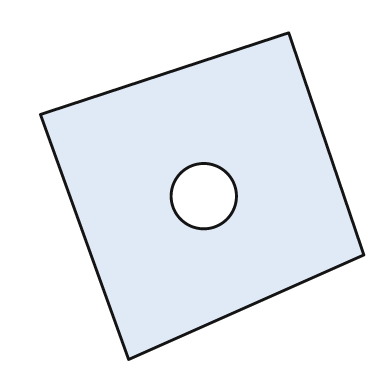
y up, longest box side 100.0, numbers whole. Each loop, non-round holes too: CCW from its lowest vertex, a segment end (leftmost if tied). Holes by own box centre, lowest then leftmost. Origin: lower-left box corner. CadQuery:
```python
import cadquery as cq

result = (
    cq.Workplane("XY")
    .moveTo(27.0, 0.0)
    .lineTo(99.0, 32.0)
    .lineTo(76.0, 100.0)
    .lineTo(0.0, 75.0)
    .close()
    .moveTo(50.0, 50.0)
    .circle(10.0)
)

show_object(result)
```